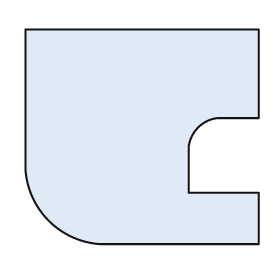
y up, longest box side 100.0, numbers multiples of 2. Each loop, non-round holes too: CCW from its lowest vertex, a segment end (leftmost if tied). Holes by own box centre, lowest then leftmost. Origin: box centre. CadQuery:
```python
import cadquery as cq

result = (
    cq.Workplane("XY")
    .moveTo(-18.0, -46.0)
    .lineTo(50.0, -46.0)
    .lineTo(50.0, -24.0)
    .lineTo(20.0, -24.0)
    .lineTo(20.0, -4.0)
    .threePointArc((24.0, 4.0), (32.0, 8.0))
    .lineTo(50.0, 8.0)
    .lineTo(50.0, 46.0)
    .lineTo(-50.0, 46.0)
    .lineTo(-50.0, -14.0)
    .threePointArc((-40.0, -36.0), (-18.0, -46.0))
    .close()
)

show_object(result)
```